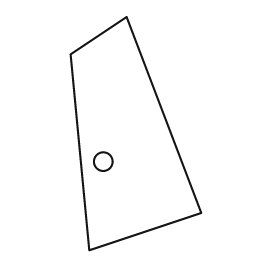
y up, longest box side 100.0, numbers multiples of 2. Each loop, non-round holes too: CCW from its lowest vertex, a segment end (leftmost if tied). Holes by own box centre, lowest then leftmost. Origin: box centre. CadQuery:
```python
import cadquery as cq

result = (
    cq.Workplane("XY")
    .moveTo(-20.0, -50.0)
    .lineTo(28.0, -34.0)
    .lineTo(-4.0, 50.0)
    .lineTo(-28.0, 34.0)
    .close()
    .moveTo(-14.0, -12.0)
    .circle(4.0)
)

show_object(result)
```